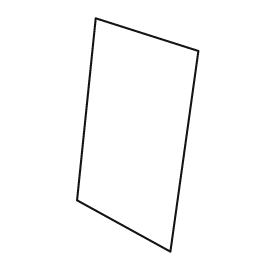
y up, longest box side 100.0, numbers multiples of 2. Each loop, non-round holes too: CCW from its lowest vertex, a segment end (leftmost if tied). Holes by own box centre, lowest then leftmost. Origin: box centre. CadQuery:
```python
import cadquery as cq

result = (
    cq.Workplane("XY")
    .moveTo(14.0, -50.0)
    .lineTo(26.0, 36.0)
    .lineTo(-18.0, 50.0)
    .lineTo(-26.0, -28.0)
    .close()
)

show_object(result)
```